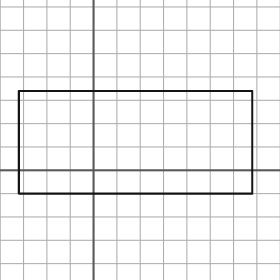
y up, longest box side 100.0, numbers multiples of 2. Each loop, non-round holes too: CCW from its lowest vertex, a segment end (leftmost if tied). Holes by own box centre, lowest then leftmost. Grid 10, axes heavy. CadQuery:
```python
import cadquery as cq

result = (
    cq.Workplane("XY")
    .moveTo(-32.0, -10.0)
    .lineTo(68.0, -10.0)
    .lineTo(68.0, 34.0)
    .lineTo(-32.0, 34.0)
    .close()
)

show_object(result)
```